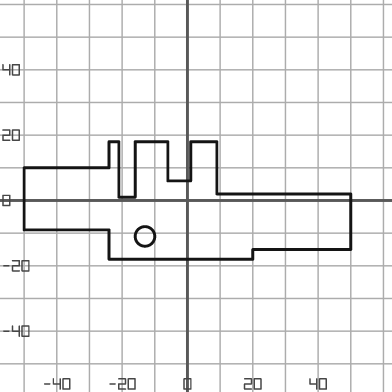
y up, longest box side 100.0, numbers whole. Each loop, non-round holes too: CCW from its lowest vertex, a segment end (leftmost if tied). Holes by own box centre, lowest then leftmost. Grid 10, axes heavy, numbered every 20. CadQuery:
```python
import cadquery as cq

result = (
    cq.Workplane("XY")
    .moveTo(-24.0, -18.0)
    .lineTo(20.0, -18.0)
    .lineTo(20.0, -15.0)
    .lineTo(50.0, -15.0)
    .lineTo(50.0, 2.0)
    .lineTo(9.0, 2.0)
    .lineTo(9.0, 18.0)
    .lineTo(1.0, 18.0)
    .lineTo(1.0, 6.0)
    .lineTo(-6.0, 6.0)
    .lineTo(-6.0, 18.0)
    .lineTo(-16.0, 18.0)
    .lineTo(-16.0, 1.0)
    .lineTo(-21.0, 1.0)
    .lineTo(-21.0, 18.0)
    .lineTo(-24.0, 18.0)
    .lineTo(-24.0, 10.0)
    .lineTo(-50.0, 10.0)
    .lineTo(-50.0, -9.0)
    .lineTo(-24.0, -9.0)
    .close()
    .moveTo(-13.0, -11.0)
    .circle(3.0)
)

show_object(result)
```